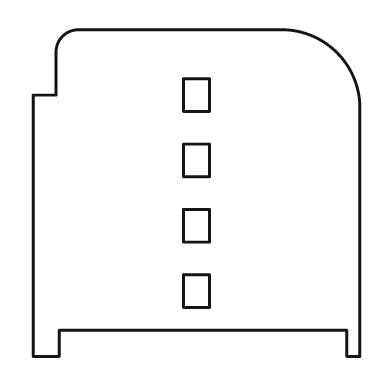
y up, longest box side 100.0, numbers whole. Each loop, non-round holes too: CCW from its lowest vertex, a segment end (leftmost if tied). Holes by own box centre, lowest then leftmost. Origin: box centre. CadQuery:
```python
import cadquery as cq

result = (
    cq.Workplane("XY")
    .moveTo(-50.0, -50.0)
    .lineTo(-42.0, -50.0)
    .lineTo(-42.0, -42.0)
    .lineTo(46.0, -42.0)
    .lineTo(46.0, -50.0)
    .lineTo(50.0, -50.0)
    .lineTo(50.0, 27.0)
    .threePointArc((43.0, 43.0), (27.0, 50.0))
    .lineTo(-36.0, 50.0)
    .threePointArc((-41.0, 48.0), (-43.0, 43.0))
    .lineTo(-43.0, 30.0)
    .lineTo(-50.0, 30.0)
    .close()
    .moveTo(-4.0, -35.0)
    .lineTo(4.0, -35.0)
    .lineTo(4.0, -25.0)
    .lineTo(-4.0, -25.0)
    .close()
    .moveTo(-4.0, -15.0)
    .lineTo(4.0, -15.0)
    .lineTo(4.0, -5.0)
    .lineTo(-4.0, -5.0)
    .close()
    .moveTo(-4.0, 5.0)
    .lineTo(4.0, 5.0)
    .lineTo(4.0, 15.0)
    .lineTo(-4.0, 15.0)
    .close()
    .moveTo(-4.0, 25.0)
    .lineTo(4.0, 25.0)
    .lineTo(4.0, 35.0)
    .lineTo(-4.0, 35.0)
    .close()
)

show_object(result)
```